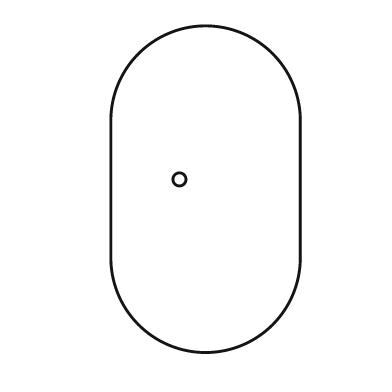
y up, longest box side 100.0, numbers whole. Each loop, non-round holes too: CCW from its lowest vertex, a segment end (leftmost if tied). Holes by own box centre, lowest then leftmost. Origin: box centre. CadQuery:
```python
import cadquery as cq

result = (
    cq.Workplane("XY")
    .moveTo(-29.0, -21.0)
    .threePointArc((0.0, -50.0), (29.0, -21.0))
    .lineTo(29.0, 21.0)
    .threePointArc((0.0, 50.0), (-29.0, 21.0))
    .close()
    .moveTo(-8.0, 3.0)
    .circle(2.0)
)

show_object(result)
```